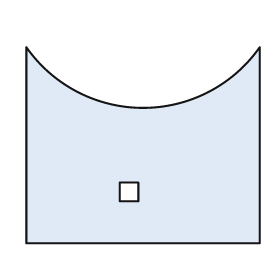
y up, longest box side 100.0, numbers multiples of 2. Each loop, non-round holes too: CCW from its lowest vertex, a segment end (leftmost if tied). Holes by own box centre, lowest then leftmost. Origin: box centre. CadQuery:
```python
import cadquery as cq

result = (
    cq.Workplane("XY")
    .moveTo(-50.0, -42.0)
    .lineTo(50.0, -42.0)
    .lineTo(50.0, 42.0)
    .threePointArc((0.0, 16.0), (-50.0, 42.0))
    .close()
    .moveTo(-10.0, -24.0)
    .lineTo(-2.0, -24.0)
    .lineTo(-2.0, -16.0)
    .lineTo(-10.0, -16.0)
    .close()
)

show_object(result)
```